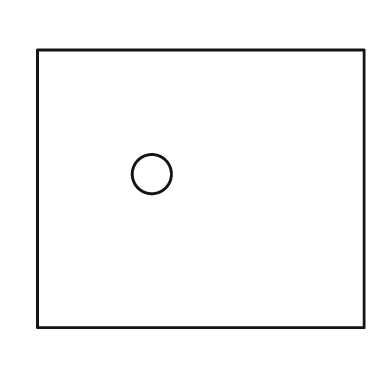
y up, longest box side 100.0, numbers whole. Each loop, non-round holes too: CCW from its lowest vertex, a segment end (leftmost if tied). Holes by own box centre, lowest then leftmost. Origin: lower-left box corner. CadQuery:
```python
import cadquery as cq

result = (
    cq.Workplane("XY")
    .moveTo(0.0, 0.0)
    .lineTo(100.0, 0.0)
    .lineTo(100.0, 85.0)
    .lineTo(0.0, 85.0)
    .close()
    .moveTo(35.0, 47.0)
    .circle(6.0)
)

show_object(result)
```